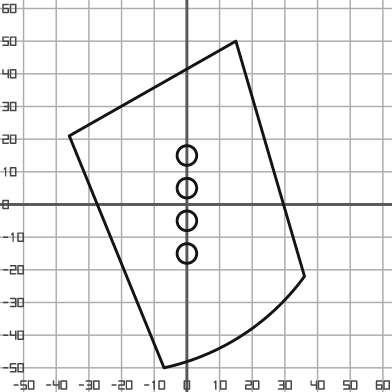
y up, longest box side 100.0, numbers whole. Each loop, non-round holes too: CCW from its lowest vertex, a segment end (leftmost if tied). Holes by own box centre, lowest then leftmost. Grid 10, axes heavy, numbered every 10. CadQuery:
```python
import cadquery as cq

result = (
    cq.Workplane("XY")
    .moveTo(-7.0, -50.0)
    .threePointArc((17.0, -40.0), (36.0, -22.0))
    .lineTo(15.0, 50.0)
    .lineTo(-36.0, 21.0)
    .close()
    .moveTo(0.0, -15.0)
    .circle(3.0)
    .moveTo(0.0, -5.0)
    .circle(3.0)
    .moveTo(0.0, 5.0)
    .circle(3.0)
    .moveTo(0.0, 15.0)
    .circle(3.0)
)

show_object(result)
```